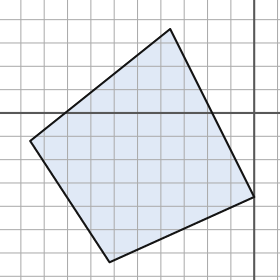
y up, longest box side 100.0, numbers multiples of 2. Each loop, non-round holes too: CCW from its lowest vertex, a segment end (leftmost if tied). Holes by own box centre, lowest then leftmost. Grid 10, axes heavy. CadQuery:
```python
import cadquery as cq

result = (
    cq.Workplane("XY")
    .moveTo(-62.0, -64.0)
    .lineTo(0.0, -36.0)
    .lineTo(-36.0, 36.0)
    .lineTo(-96.0, -12.0)
    .close()
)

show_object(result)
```